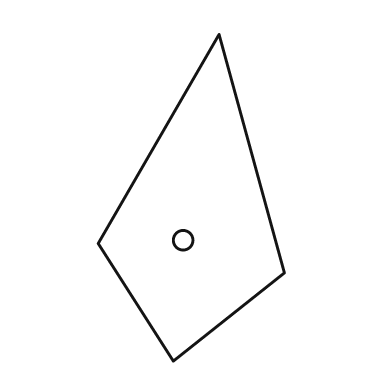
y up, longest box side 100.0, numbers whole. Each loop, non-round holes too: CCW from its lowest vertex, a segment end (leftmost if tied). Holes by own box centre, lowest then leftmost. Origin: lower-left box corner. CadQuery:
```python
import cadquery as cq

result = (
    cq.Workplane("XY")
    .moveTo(23.0, 0.0)
    .lineTo(57.0, 27.0)
    .lineTo(37.0, 100.0)
    .lineTo(0.0, 36.0)
    .close()
    .moveTo(26.0, 37.0)
    .circle(3.0)
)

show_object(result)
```